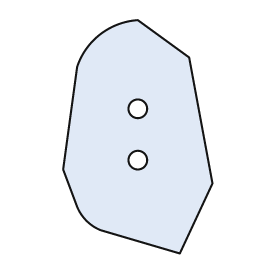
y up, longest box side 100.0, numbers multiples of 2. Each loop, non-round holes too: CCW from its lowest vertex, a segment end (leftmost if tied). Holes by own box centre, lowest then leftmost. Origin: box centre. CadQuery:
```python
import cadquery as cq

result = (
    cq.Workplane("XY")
    .moveTo(18.0, -50.0)
    .lineTo(32.0, -20.0)
    .lineTo(22.0, 34.0)
    .lineTo(0.0, 50.0)
    .threePointArc((-16.0, 44.0), (-26.0, 30.0))
    .lineTo(-32.0, -14.0)
    .lineTo(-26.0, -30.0)
    .threePointArc((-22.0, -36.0), (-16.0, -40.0))
    .close()
    .moveTo(0.0, -10.0)
    .circle(4.0)
    .moveTo(0.0, 12.0)
    .circle(4.0)
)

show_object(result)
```